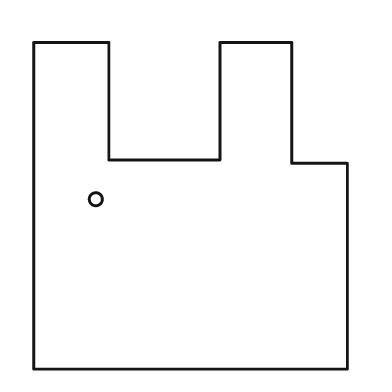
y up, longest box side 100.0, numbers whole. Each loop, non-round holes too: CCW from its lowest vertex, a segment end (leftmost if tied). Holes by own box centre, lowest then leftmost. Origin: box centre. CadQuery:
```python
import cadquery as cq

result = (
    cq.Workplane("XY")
    .moveTo(-48.0, -50.0)
    .lineTo(48.0, -50.0)
    .lineTo(48.0, 13.0)
    .lineTo(31.0, 13.0)
    .lineTo(31.0, 50.0)
    .lineTo(9.0, 50.0)
    .lineTo(9.0, 14.0)
    .lineTo(-25.0, 14.0)
    .lineTo(-25.0, 50.0)
    .lineTo(-48.0, 50.0)
    .close()
    .moveTo(-29.0, 2.0)
    .circle(2.0)
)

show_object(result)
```